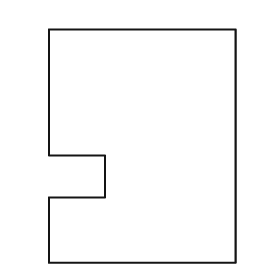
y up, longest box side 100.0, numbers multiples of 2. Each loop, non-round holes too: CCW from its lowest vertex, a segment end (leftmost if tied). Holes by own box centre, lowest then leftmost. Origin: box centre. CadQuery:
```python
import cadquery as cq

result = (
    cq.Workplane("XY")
    .moveTo(-40.0, -50.0)
    .lineTo(40.0, -50.0)
    .lineTo(40.0, 50.0)
    .lineTo(-40.0, 50.0)
    .lineTo(-40.0, -4.0)
    .lineTo(-16.0, -4.0)
    .lineTo(-16.0, -22.0)
    .lineTo(-40.0, -22.0)
    .close()
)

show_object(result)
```